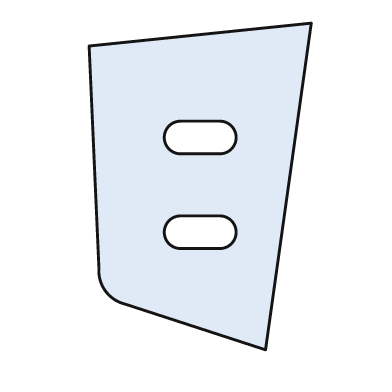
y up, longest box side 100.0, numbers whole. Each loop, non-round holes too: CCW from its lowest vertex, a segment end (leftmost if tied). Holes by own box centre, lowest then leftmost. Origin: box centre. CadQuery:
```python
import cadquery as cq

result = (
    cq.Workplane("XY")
    .moveTo(20.0, -50.0)
    .lineTo(34.0, 50.0)
    .lineTo(-34.0, 43.0)
    .lineTo(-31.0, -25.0)
    .threePointArc((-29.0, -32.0), (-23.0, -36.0))
    .close()
    .moveTo(-6.0, -19.0)
    .lineTo(6.0, -19.0)
    .threePointArc((11.0, -14.0), (6.0, -9.0))
    .lineTo(-6.0, -9.0)
    .threePointArc((-11.0, -14.0), (-6.0, -19.0))
    .close()
    .moveTo(-6.0, 10.0)
    .lineTo(6.0, 10.0)
    .threePointArc((11.0, 15.0), (6.0, 20.0))
    .lineTo(-6.0, 20.0)
    .threePointArc((-11.0, 15.0), (-6.0, 10.0))
    .close()
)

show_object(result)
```